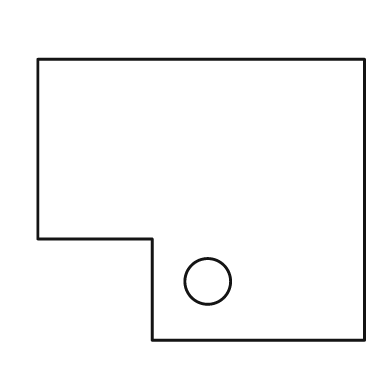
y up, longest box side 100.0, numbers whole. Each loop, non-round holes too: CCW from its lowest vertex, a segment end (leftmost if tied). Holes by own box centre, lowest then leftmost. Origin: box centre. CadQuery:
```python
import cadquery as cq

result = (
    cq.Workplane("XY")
    .moveTo(-15.0, -43.0)
    .lineTo(50.0, -43.0)
    .lineTo(50.0, 43.0)
    .lineTo(-50.0, 43.0)
    .lineTo(-50.0, -12.0)
    .lineTo(-15.0, -12.0)
    .close()
    .moveTo(2.0, -25.0)
    .circle(7.0)
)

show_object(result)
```